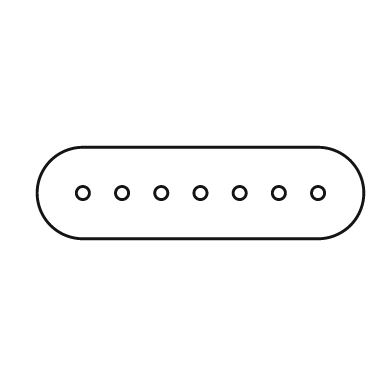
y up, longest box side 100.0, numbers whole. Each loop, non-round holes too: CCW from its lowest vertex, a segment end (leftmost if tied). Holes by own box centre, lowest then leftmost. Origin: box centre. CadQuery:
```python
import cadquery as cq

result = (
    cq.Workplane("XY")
    .moveTo(-36.0, -14.0)
    .lineTo(36.0, -14.0)
    .threePointArc((50.0, 0.0), (36.0, 14.0))
    .lineTo(-36.0, 14.0)
    .threePointArc((-50.0, 0.0), (-36.0, -14.0))
    .close()
    .moveTo(-36.0, 0.0)
    .circle(2.0)
    .moveTo(-24.0, 0.0)
    .circle(2.0)
    .moveTo(-12.0, 0.0)
    .circle(2.0)
    .moveTo(0.0, 0.0)
    .circle(2.0)
    .moveTo(12.0, 0.0)
    .circle(2.0)
    .moveTo(24.0, 0.0)
    .circle(2.0)
    .moveTo(36.0, 0.0)
    .circle(2.0)
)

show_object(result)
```